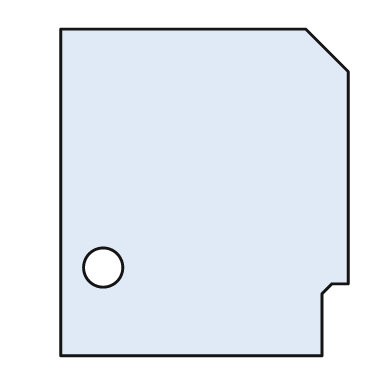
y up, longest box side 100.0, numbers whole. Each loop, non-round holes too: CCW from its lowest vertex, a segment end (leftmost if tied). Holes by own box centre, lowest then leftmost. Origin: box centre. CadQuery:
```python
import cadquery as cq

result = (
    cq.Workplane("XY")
    .moveTo(-44.0, -50.0)
    .lineTo(36.0, -50.0)
    .lineTo(36.0, -31.0)
    .lineTo(39.0, -28.0)
    .lineTo(44.0, -28.0)
    .lineTo(44.0, 37.0)
    .lineTo(31.0, 50.0)
    .lineTo(-44.0, 50.0)
    .close()
    .moveTo(-31.0, -23.0)
    .circle(6.0)
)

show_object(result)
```